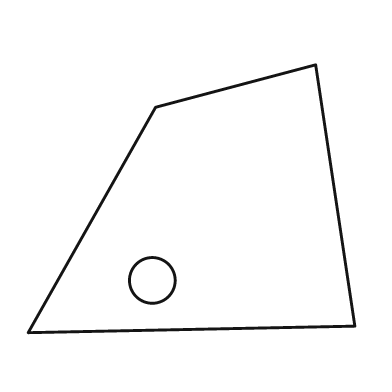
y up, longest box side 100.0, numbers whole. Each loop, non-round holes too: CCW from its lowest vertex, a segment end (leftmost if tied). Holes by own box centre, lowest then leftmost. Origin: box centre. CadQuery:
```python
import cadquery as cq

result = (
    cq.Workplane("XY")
    .moveTo(-50.0, -41.0)
    .lineTo(50.0, -39.0)
    .lineTo(38.0, 41.0)
    .lineTo(-11.0, 28.0)
    .close()
    .moveTo(-12.0, -25.0)
    .circle(7.0)
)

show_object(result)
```